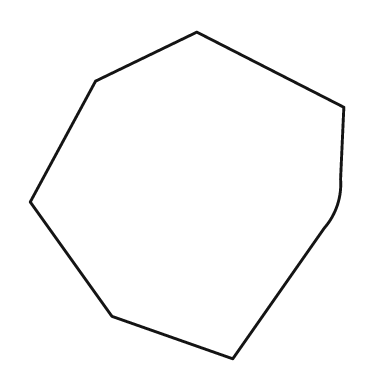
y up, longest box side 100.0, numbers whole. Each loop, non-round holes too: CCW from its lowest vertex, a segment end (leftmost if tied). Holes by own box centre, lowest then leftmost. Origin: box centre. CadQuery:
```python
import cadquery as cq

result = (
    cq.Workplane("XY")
    .moveTo(14.0, -50.0)
    .lineTo(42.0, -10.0)
    .threePointArc((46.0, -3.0), (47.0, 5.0))
    .lineTo(48.0, 27.0)
    .lineTo(3.0, 50.0)
    .lineTo(-28.0, 35.0)
    .lineTo(-48.0, -2.0)
    .lineTo(-23.0, -37.0)
    .close()
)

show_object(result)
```